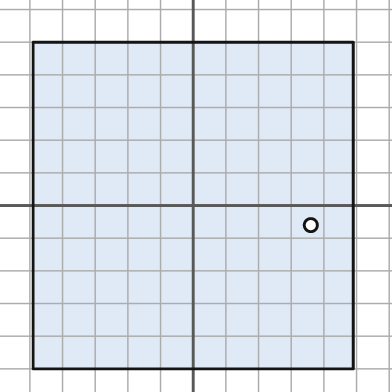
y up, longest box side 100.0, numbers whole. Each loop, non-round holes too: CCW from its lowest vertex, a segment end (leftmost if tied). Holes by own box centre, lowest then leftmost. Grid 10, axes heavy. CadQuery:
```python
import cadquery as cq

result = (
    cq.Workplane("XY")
    .moveTo(-49.0, -50.0)
    .lineTo(49.0, -50.0)
    .lineTo(49.0, 50.0)
    .lineTo(-49.0, 50.0)
    .close()
    .moveTo(36.0, -6.0)
    .circle(2.0)
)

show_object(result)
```